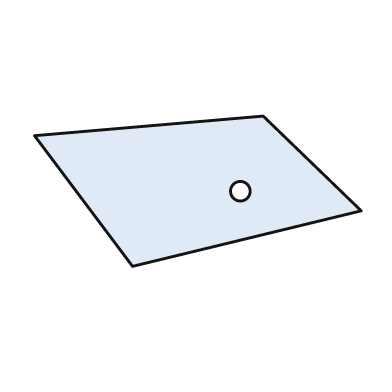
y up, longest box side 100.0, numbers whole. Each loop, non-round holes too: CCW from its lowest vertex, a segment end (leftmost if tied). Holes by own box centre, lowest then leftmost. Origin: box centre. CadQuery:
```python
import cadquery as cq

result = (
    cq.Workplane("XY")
    .moveTo(-20.0, -23.0)
    .lineTo(50.0, -6.0)
    .lineTo(20.0, 23.0)
    .lineTo(-50.0, 17.0)
    .close()
    .moveTo(13.0, 0.0)
    .circle(3.0)
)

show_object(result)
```